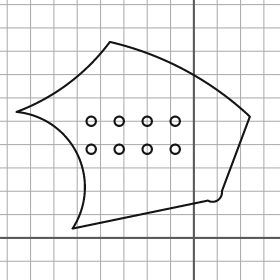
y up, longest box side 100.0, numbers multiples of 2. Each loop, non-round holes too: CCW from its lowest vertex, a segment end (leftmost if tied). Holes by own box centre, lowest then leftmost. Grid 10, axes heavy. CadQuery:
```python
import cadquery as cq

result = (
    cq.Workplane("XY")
    .moveTo(-52.0, 4.0)
    .lineTo(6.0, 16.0)
    .threePointArc((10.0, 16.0), (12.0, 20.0))
    .lineTo(24.0, 52.0)
    .threePointArc((-4.0, 72.0), (-36.0, 84.0))
    .threePointArc((-54.0, 66.0), (-76.0, 54.0))
    .threePointArc((-50.0, 36.0), (-52.0, 4.0))
    .close()
    .moveTo(-44.0, 38.0)
    .circle(2.0)
    .moveTo(-32.0, 38.0)
    .circle(2.0)
    .moveTo(-20.0, 38.0)
    .circle(2.0)
    .moveTo(-8.0, 38.0)
    .circle(2.0)
    .moveTo(-44.0, 50.0)
    .circle(2.0)
    .moveTo(-32.0, 50.0)
    .circle(2.0)
    .moveTo(-20.0, 50.0)
    .circle(2.0)
    .moveTo(-8.0, 50.0)
    .circle(2.0)
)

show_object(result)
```